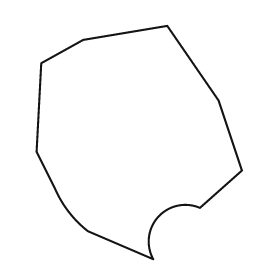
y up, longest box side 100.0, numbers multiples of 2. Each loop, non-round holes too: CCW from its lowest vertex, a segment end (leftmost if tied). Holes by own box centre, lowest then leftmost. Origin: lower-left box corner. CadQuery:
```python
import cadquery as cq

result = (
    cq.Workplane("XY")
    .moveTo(50.0, 0.0)
    .threePointArc((52.0, 18.0), (70.0, 22.0))
    .lineTo(88.0, 38.0)
    .lineTo(78.0, 68.0)
    .lineTo(56.0, 100.0)
    .lineTo(20.0, 94.0)
    .lineTo(2.0, 84.0)
    .lineTo(0.0, 46.0)
    .lineTo(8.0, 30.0)
    .threePointArc((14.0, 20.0), (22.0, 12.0))
    .close()
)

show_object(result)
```